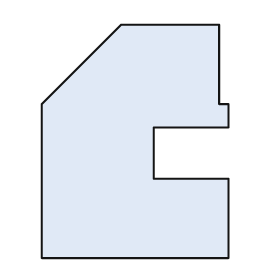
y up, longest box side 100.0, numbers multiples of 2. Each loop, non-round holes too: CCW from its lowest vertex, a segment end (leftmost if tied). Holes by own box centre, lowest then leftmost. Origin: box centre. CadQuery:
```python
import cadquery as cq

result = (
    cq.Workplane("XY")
    .moveTo(-40.0, -50.0)
    .lineTo(40.0, -50.0)
    .lineTo(40.0, -16.0)
    .lineTo(8.0, -16.0)
    .lineTo(8.0, 6.0)
    .lineTo(40.0, 6.0)
    .lineTo(40.0, 16.0)
    .lineTo(36.0, 16.0)
    .lineTo(36.0, 50.0)
    .lineTo(-6.0, 50.0)
    .lineTo(-40.0, 16.0)
    .close()
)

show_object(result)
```